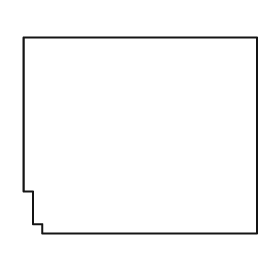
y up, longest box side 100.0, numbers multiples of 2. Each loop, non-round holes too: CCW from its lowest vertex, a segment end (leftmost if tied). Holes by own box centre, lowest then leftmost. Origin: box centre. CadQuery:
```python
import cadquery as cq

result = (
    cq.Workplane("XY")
    .moveTo(-42.0, -42.0)
    .lineTo(50.0, -42.0)
    .lineTo(50.0, 42.0)
    .lineTo(-50.0, 42.0)
    .lineTo(-50.0, -24.0)
    .lineTo(-46.0, -24.0)
    .lineTo(-46.0, -38.0)
    .lineTo(-42.0, -38.0)
    .close()
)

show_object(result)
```